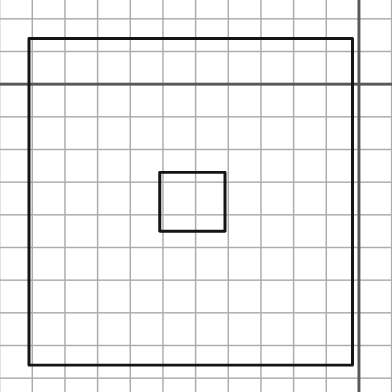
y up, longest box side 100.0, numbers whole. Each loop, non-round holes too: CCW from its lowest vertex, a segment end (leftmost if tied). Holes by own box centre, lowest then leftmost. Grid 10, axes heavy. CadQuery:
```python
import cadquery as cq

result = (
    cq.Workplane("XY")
    .moveTo(-101.0, -86.0)
    .lineTo(-2.0, -86.0)
    .lineTo(-2.0, 14.0)
    .lineTo(-101.0, 14.0)
    .close()
    .moveTo(-61.0, -45.0)
    .lineTo(-41.0, -45.0)
    .lineTo(-41.0, -27.0)
    .lineTo(-61.0, -27.0)
    .close()
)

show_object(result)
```